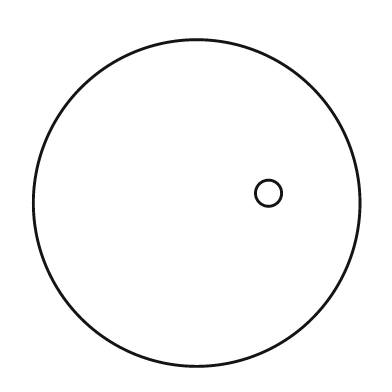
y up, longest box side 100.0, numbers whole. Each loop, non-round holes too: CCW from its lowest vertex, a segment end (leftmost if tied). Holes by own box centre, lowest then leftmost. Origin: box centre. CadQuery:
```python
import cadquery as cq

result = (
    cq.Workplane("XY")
    .moveTo(0.0, 0.0)
    .circle(50.0)
    .moveTo(22.0, 3.0)
    .circle(4.0)
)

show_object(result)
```